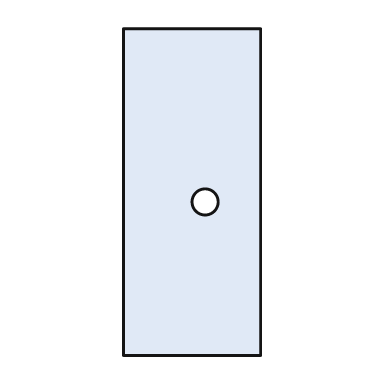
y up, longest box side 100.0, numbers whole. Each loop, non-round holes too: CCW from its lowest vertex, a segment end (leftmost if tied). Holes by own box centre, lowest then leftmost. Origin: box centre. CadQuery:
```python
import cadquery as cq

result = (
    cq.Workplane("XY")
    .moveTo(-21.0, -50.0)
    .lineTo(21.0, -50.0)
    .lineTo(21.0, 50.0)
    .lineTo(-21.0, 50.0)
    .close()
    .moveTo(4.0, -3.0)
    .circle(4.0)
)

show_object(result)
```